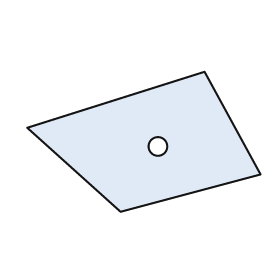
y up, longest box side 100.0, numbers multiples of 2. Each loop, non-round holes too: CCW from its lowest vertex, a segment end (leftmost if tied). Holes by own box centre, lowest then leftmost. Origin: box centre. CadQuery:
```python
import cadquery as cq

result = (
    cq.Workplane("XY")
    .moveTo(-10.0, -30.0)
    .lineTo(50.0, -14.0)
    .lineTo(26.0, 30.0)
    .lineTo(-50.0, 6.0)
    .close()
    .moveTo(6.0, -2.0)
    .circle(4.0)
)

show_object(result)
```